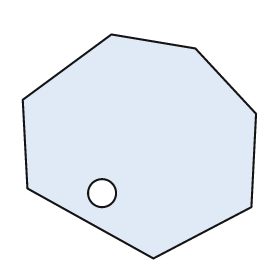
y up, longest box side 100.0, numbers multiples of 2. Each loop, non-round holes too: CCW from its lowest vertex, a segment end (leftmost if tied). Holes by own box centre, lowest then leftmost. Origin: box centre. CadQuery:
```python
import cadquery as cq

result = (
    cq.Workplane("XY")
    .moveTo(6.0, -48.0)
    .lineTo(48.0, -26.0)
    .lineTo(50.0, 14.0)
    .lineTo(24.0, 42.0)
    .lineTo(-12.0, 48.0)
    .lineTo(-50.0, 20.0)
    .lineTo(-48.0, -18.0)
    .close()
    .moveTo(-16.0, -20.0)
    .circle(6.0)
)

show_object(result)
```